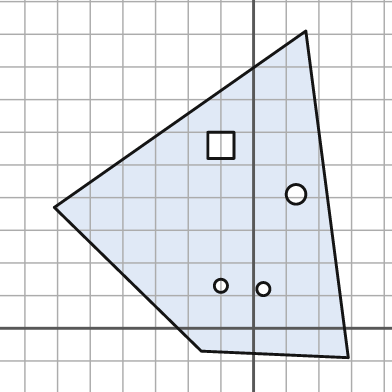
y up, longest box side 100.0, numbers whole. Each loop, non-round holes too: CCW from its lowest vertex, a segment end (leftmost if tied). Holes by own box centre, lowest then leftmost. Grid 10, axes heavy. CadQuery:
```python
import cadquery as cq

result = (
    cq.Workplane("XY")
    .moveTo(29.0, -9.0)
    .lineTo(16.0, 91.0)
    .lineTo(-61.0, 37.0)
    .lineTo(-16.0, -7.0)
    .close()
    .moveTo(3.0, 12.0)
    .circle(2.0)
    .moveTo(-10.0, 13.0)
    .circle(2.0)
    .moveTo(13.0, 41.0)
    .circle(3.0)
    .moveTo(-14.0, 52.0)
    .lineTo(-6.0, 52.0)
    .lineTo(-6.0, 60.0)
    .lineTo(-14.0, 60.0)
    .close()
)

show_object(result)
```